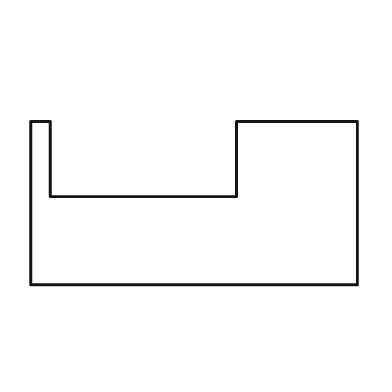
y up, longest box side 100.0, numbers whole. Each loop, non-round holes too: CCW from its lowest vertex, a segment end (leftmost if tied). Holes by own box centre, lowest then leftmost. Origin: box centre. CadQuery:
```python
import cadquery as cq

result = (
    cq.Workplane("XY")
    .moveTo(-50.0, -25.0)
    .lineTo(50.0, -25.0)
    .lineTo(50.0, 25.0)
    .lineTo(13.0, 25.0)
    .lineTo(13.0, 2.0)
    .lineTo(-44.0, 2.0)
    .lineTo(-44.0, 25.0)
    .lineTo(-50.0, 25.0)
    .close()
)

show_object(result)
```